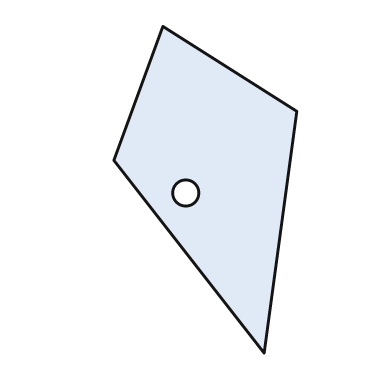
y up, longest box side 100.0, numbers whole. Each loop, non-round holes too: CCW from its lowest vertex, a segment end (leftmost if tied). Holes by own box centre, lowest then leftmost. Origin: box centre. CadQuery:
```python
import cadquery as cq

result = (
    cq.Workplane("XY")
    .moveTo(18.0, -50.0)
    .lineTo(28.0, 24.0)
    .lineTo(-13.0, 50.0)
    .lineTo(-28.0, 9.0)
    .close()
    .moveTo(-6.0, -1.0)
    .circle(4.0)
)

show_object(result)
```